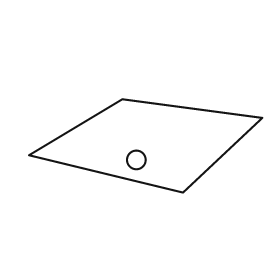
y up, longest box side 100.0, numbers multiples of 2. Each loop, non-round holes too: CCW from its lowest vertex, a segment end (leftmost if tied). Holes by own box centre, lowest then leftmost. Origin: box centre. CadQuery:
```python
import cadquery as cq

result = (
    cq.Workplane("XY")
    .moveTo(16.0, -20.0)
    .lineTo(50.0, 12.0)
    .lineTo(-10.0, 20.0)
    .lineTo(-50.0, -4.0)
    .close()
    .moveTo(-4.0, -6.0)
    .circle(4.0)
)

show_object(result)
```